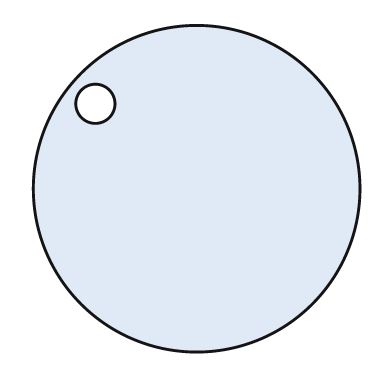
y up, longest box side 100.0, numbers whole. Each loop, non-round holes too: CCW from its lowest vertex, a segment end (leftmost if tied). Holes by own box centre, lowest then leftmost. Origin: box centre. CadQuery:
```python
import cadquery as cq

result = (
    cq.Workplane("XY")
    .moveTo(0.0, 0.0)
    .circle(50.0)
    .moveTo(-31.0, 26.0)
    .circle(6.0)
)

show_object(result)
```